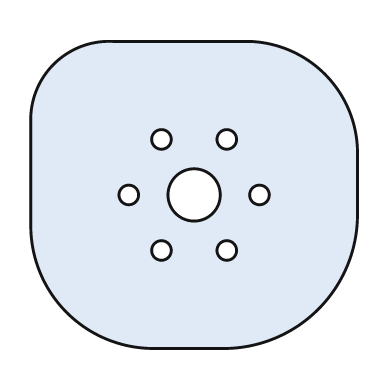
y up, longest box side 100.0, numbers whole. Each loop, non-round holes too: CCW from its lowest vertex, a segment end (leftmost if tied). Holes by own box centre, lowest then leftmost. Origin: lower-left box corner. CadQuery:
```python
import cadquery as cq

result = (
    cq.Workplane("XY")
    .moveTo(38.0, 0.0)
    .lineTo(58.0, 0.0)
    .threePointArc((88.0, 12.0), (100.0, 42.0))
    .lineTo(100.0, 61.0)
    .threePointArc((90.0, 84.0), (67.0, 94.0))
    .lineTo(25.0, 94.0)
    .threePointArc((7.0, 87.0), (0.0, 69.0))
    .lineTo(0.0, 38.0)
    .threePointArc((11.0, 11.0), (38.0, 0.0))
    .close()
    .moveTo(40.0, 30.0)
    .circle(3.0)
    .moveTo(60.0, 30.0)
    .circle(3.0)
    .moveTo(30.0, 47.0)
    .circle(3.0)
    .moveTo(50.0, 47.0)
    .circle(8.0)
    .moveTo(70.0, 47.0)
    .circle(3.0)
    .moveTo(40.0, 64.0)
    .circle(3.0)
    .moveTo(60.0, 64.0)
    .circle(3.0)
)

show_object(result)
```